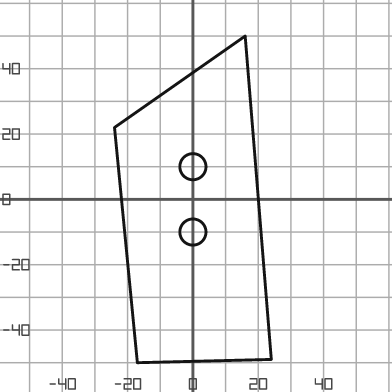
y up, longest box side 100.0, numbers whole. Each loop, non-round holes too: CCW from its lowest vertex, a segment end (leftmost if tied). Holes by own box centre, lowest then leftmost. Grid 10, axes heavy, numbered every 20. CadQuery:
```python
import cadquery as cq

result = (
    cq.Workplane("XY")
    .moveTo(-17.0, -50.0)
    .lineTo(24.0, -49.0)
    .lineTo(16.0, 50.0)
    .lineTo(-24.0, 22.0)
    .close()
    .moveTo(0.0, -10.0)
    .circle(4.0)
    .moveTo(0.0, 10.0)
    .circle(4.0)
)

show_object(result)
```